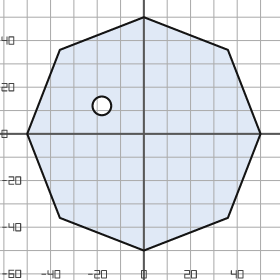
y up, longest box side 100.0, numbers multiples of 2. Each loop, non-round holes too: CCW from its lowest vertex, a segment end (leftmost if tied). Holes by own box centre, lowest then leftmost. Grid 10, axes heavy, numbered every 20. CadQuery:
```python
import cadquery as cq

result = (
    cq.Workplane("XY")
    .moveTo(0.0, -50.0)
    .lineTo(36.0, -36.0)
    .lineTo(50.0, 0.0)
    .lineTo(36.0, 36.0)
    .lineTo(0.0, 50.0)
    .lineTo(-36.0, 36.0)
    .lineTo(-50.0, 0.0)
    .lineTo(-36.0, -36.0)
    .close()
    .moveTo(-18.0, 12.0)
    .circle(4.0)
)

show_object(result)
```